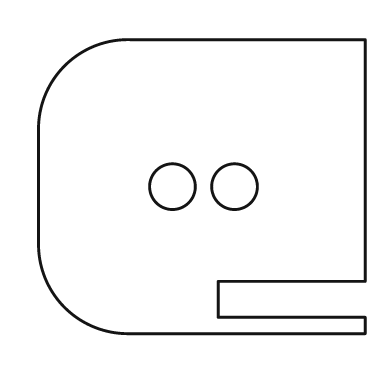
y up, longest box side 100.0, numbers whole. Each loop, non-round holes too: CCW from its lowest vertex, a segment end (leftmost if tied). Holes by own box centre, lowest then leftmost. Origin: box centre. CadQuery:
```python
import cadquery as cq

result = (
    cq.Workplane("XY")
    .moveTo(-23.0, -45.0)
    .lineTo(50.0, -45.0)
    .lineTo(50.0, -40.0)
    .lineTo(5.0, -40.0)
    .lineTo(5.0, -29.0)
    .lineTo(50.0, -29.0)
    .lineTo(50.0, 45.0)
    .lineTo(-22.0, 45.0)
    .threePointArc((-42.0, 37.0), (-50.0, 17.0))
    .lineTo(-50.0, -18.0)
    .threePointArc((-42.0, -37.0), (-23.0, -45.0))
    .close()
    .moveTo(-9.0, 0.0)
    .circle(7.0)
    .moveTo(10.0, 0.0)
    .circle(7.0)
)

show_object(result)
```